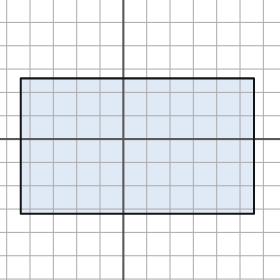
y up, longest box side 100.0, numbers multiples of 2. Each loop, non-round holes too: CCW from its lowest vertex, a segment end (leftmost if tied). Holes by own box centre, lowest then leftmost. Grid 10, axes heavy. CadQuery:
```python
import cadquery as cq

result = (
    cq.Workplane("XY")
    .moveTo(-44.0, -32.0)
    .lineTo(56.0, -32.0)
    .lineTo(56.0, 26.0)
    .lineTo(-44.0, 26.0)
    .close()
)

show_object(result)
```